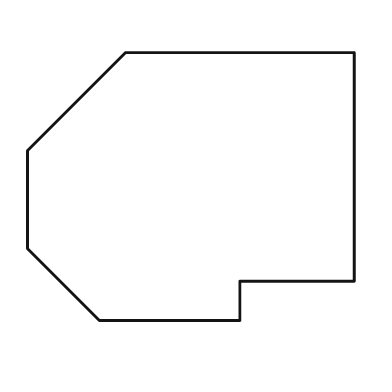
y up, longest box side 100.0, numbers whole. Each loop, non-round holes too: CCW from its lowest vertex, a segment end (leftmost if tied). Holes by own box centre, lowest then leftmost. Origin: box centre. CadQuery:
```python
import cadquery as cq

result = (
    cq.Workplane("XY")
    .moveTo(-28.0, -41.0)
    .lineTo(15.0, -41.0)
    .lineTo(15.0, -29.0)
    .lineTo(50.0, -29.0)
    .lineTo(50.0, 41.0)
    .lineTo(-20.0, 41.0)
    .lineTo(-50.0, 11.0)
    .lineTo(-50.0, -19.0)
    .close()
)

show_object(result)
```